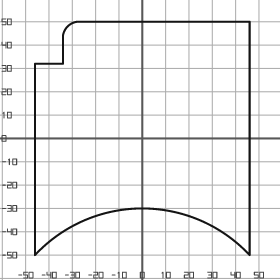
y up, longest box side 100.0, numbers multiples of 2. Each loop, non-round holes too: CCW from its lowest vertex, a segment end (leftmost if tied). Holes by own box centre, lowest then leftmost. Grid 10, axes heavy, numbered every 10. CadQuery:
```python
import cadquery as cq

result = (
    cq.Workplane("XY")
    .moveTo(-46.0, -50.0)
    .threePointArc((0.0, -30.0), (46.0, -50.0))
    .lineTo(46.0, 50.0)
    .lineTo(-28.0, 50.0)
    .threePointArc((-32.0, 48.0), (-34.0, 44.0))
    .lineTo(-34.0, 32.0)
    .lineTo(-46.0, 32.0)
    .close()
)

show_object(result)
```